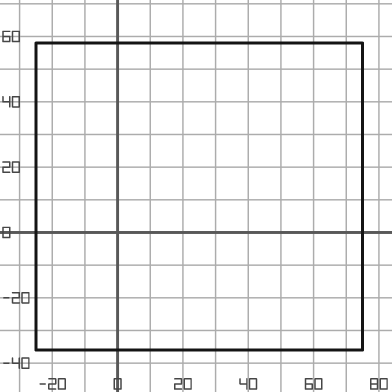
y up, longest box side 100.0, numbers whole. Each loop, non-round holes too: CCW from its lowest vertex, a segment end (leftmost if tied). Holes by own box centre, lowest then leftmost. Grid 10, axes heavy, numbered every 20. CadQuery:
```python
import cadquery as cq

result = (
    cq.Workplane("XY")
    .moveTo(-25.0, -36.0)
    .lineTo(75.0, -36.0)
    .lineTo(75.0, 58.0)
    .lineTo(-25.0, 58.0)
    .close()
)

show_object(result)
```